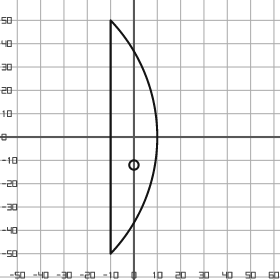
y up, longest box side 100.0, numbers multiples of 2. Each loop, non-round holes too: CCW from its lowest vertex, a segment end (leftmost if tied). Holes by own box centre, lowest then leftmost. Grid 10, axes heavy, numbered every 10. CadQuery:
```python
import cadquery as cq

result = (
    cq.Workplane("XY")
    .moveTo(-10.0, -50.0)
    .threePointArc((10.0, 0.0), (-10.0, 50.0))
    .close()
    .moveTo(0.0, -12.0)
    .circle(2.0)
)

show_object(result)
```